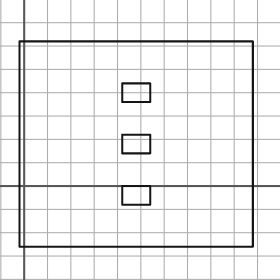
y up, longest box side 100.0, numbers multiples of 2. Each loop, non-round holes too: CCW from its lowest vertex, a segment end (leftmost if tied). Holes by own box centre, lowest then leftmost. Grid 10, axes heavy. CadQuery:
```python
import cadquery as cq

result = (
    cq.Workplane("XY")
    .moveTo(-2.0, -26.0)
    .lineTo(98.0, -26.0)
    .lineTo(98.0, 62.0)
    .lineTo(-2.0, 62.0)
    .close()
    .moveTo(42.0, -8.0)
    .lineTo(54.0, -8.0)
    .lineTo(54.0, 0.0)
    .lineTo(42.0, 0.0)
    .close()
    .moveTo(42.0, 14.0)
    .lineTo(54.0, 14.0)
    .lineTo(54.0, 22.0)
    .lineTo(42.0, 22.0)
    .close()
    .moveTo(42.0, 36.0)
    .lineTo(54.0, 36.0)
    .lineTo(54.0, 44.0)
    .lineTo(42.0, 44.0)
    .close()
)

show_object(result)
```